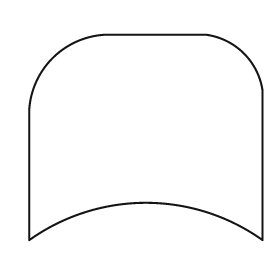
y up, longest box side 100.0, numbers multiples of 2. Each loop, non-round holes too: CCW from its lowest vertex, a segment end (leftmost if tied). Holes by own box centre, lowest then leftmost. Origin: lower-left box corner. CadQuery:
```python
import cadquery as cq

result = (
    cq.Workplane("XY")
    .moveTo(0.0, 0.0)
    .threePointArc((50.0, 16.0), (100.0, 0.0))
    .lineTo(100.0, 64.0)
    .threePointArc((92.0, 80.0), (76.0, 88.0))
    .lineTo(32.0, 88.0)
    .threePointArc((10.0, 78.0), (0.0, 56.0))
    .close()
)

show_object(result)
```